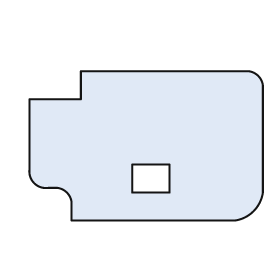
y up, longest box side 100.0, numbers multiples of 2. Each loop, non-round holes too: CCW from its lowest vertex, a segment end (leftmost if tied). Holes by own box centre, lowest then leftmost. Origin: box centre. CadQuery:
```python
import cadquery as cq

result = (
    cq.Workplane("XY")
    .moveTo(-32.0, -32.0)
    .lineTo(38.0, -32.0)
    .threePointArc((46.0, -28.0), (50.0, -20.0))
    .lineTo(50.0, 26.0)
    .threePointArc((48.0, 30.0), (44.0, 32.0))
    .lineTo(-28.0, 32.0)
    .lineTo(-28.0, 20.0)
    .lineTo(-50.0, 20.0)
    .lineTo(-50.0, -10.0)
    .threePointArc((-48.0, -16.0), (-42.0, -18.0))
    .lineTo(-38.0, -18.0)
    .threePointArc((-34.0, -20.0), (-32.0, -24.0))
    .close()
    .moveTo(-6.0, -20.0)
    .lineTo(10.0, -20.0)
    .lineTo(10.0, -8.0)
    .lineTo(-6.0, -8.0)
    .close()
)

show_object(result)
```